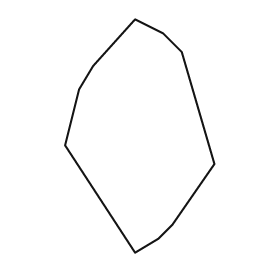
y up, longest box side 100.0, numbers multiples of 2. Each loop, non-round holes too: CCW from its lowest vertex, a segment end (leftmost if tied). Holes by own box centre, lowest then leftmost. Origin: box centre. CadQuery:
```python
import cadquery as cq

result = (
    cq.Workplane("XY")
    .moveTo(-2.0, -50.0)
    .lineTo(8.0, -44.0)
    .lineTo(14.0, -38.0)
    .lineTo(32.0, -12.0)
    .lineTo(18.0, 36.0)
    .lineTo(10.0, 44.0)
    .lineTo(-2.0, 50.0)
    .lineTo(-20.0, 30.0)
    .lineTo(-26.0, 20.0)
    .lineTo(-32.0, -4.0)
    .close()
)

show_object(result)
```